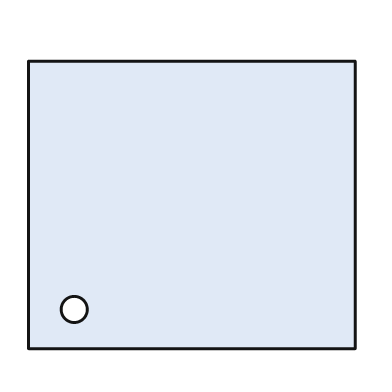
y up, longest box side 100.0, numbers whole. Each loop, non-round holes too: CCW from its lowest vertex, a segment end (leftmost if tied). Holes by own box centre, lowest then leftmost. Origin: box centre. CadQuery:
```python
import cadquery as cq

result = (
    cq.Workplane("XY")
    .moveTo(-50.0, -44.0)
    .lineTo(50.0, -44.0)
    .lineTo(50.0, 44.0)
    .lineTo(-50.0, 44.0)
    .close()
    .moveTo(-36.0, -32.0)
    .circle(4.0)
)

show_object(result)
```